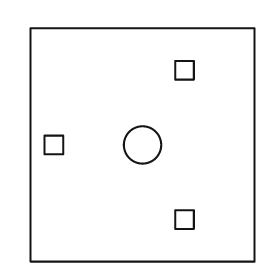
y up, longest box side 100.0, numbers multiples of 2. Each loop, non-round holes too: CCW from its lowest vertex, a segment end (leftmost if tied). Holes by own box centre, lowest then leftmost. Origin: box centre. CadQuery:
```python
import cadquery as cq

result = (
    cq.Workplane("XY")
    .moveTo(-48.0, -50.0)
    .lineTo(48.0, -50.0)
    .lineTo(48.0, 50.0)
    .lineTo(-48.0, 50.0)
    .close()
    .moveTo(14.0, -36.0)
    .lineTo(22.0, -36.0)
    .lineTo(22.0, -28.0)
    .lineTo(14.0, -28.0)
    .close()
    .moveTo(-42.0, -4.0)
    .lineTo(-34.0, -4.0)
    .lineTo(-34.0, 4.0)
    .lineTo(-42.0, 4.0)
    .close()
    .moveTo(0.0, 0.0)
    .circle(8.0)
    .moveTo(14.0, 28.0)
    .lineTo(22.0, 28.0)
    .lineTo(22.0, 36.0)
    .lineTo(14.0, 36.0)
    .close()
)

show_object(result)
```